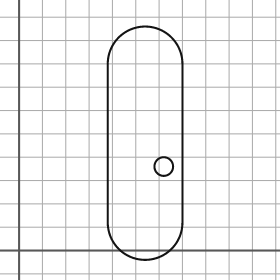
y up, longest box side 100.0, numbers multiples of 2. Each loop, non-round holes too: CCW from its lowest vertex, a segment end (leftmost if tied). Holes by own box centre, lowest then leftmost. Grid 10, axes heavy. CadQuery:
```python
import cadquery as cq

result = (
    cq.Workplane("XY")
    .moveTo(38.0, 12.0)
    .threePointArc((54.0, -4.0), (70.0, 12.0))
    .lineTo(70.0, 80.0)
    .threePointArc((54.0, 96.0), (38.0, 80.0))
    .close()
    .moveTo(62.0, 36.0)
    .circle(4.0)
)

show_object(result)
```